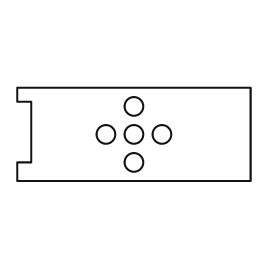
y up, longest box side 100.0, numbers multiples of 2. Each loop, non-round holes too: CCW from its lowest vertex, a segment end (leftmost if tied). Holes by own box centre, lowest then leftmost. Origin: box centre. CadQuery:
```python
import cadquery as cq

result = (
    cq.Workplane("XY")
    .moveTo(-50.0, -20.0)
    .lineTo(50.0, -20.0)
    .lineTo(50.0, 20.0)
    .lineTo(-50.0, 20.0)
    .lineTo(-50.0, 14.0)
    .lineTo(-44.0, 14.0)
    .lineTo(-44.0, -12.0)
    .lineTo(-50.0, -12.0)
    .close()
    .moveTo(0.0, -12.0)
    .circle(4.0)
    .moveTo(-12.0, 0.0)
    .circle(4.0)
    .moveTo(0.0, 0.0)
    .circle(4.0)
    .moveTo(12.0, 0.0)
    .circle(4.0)
    .moveTo(0.0, 12.0)
    .circle(4.0)
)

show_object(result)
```